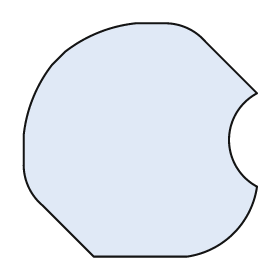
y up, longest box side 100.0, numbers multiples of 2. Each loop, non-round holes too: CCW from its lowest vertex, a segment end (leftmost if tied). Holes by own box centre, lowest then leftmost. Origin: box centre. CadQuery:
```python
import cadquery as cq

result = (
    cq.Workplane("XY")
    .moveTo(-20.0, -50.0)
    .lineTo(20.0, -50.0)
    .threePointArc((40.0, -40.0), (50.0, -20.0))
    .threePointArc((38.0, 0.0), (50.0, 20.0))
    .lineTo(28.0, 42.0)
    .threePointArc((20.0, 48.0), (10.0, 50.0))
    .lineTo(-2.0, 50.0)
    .threePointArc((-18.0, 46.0), (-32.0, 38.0))
    .lineTo(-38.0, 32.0)
    .threePointArc((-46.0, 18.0), (-50.0, 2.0))
    .lineTo(-50.0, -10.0)
    .threePointArc((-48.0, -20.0), (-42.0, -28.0))
    .close()
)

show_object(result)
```